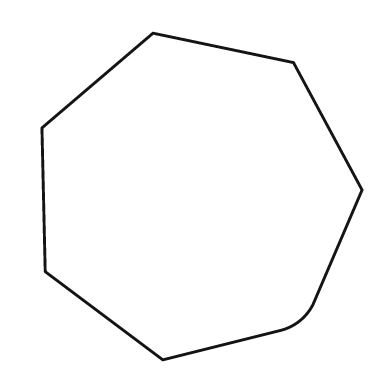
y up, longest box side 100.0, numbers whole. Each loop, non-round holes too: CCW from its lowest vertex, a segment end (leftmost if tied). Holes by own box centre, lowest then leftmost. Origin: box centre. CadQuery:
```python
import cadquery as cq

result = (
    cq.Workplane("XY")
    .moveTo(-12.0, -50.0)
    .lineTo(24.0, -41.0)
    .threePointArc((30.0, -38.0), (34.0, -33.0))
    .lineTo(49.0, 2.0)
    .lineTo(28.0, 41.0)
    .lineTo(-15.0, 50.0)
    .lineTo(-49.0, 21.0)
    .lineTo(-48.0, -23.0)
    .close()
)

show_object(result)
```